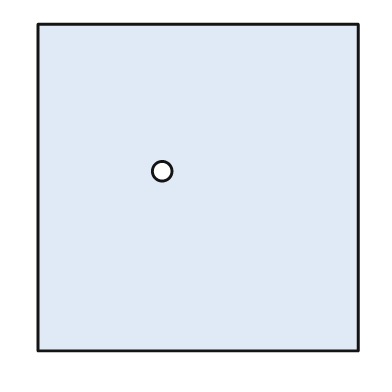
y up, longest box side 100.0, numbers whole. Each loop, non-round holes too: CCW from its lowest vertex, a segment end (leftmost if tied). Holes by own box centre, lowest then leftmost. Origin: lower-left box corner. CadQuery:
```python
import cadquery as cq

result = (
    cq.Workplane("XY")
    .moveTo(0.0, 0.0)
    .lineTo(98.0, 0.0)
    .lineTo(98.0, 100.0)
    .lineTo(0.0, 100.0)
    .close()
    .moveTo(38.0, 55.0)
    .circle(3.0)
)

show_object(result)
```